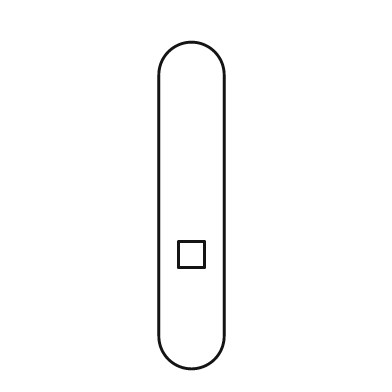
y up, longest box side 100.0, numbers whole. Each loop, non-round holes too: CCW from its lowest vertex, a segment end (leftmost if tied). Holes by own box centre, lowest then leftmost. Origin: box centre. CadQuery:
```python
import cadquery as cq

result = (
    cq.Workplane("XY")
    .moveTo(-10.0, -40.0)
    .threePointArc((0.0, -50.0), (10.0, -40.0))
    .lineTo(10.0, 40.0)
    .threePointArc((0.0, 50.0), (-10.0, 40.0))
    .close()
    .moveTo(-4.0, -19.0)
    .lineTo(4.0, -19.0)
    .lineTo(4.0, -11.0)
    .lineTo(-4.0, -11.0)
    .close()
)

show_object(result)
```